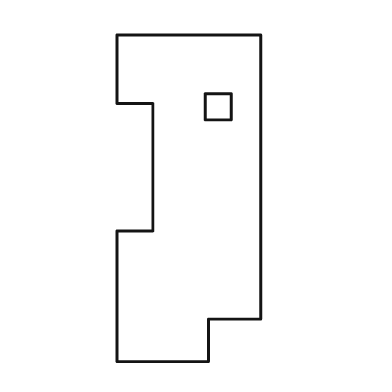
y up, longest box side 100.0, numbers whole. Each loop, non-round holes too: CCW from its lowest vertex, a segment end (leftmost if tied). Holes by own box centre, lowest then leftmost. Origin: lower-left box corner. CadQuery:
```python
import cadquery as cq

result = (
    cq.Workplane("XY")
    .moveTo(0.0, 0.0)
    .lineTo(28.0, 0.0)
    .lineTo(28.0, 13.0)
    .lineTo(44.0, 13.0)
    .lineTo(44.0, 100.0)
    .lineTo(0.0, 100.0)
    .lineTo(0.0, 79.0)
    .lineTo(11.0, 79.0)
    .lineTo(11.0, 40.0)
    .lineTo(0.0, 40.0)
    .close()
    .moveTo(27.0, 74.0)
    .lineTo(35.0, 74.0)
    .lineTo(35.0, 82.0)
    .lineTo(27.0, 82.0)
    .close()
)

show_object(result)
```